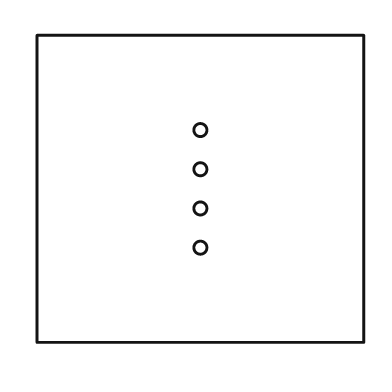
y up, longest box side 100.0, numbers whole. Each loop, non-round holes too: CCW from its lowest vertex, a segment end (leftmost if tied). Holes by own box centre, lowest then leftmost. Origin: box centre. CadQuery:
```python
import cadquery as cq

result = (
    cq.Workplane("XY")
    .moveTo(-50.0, -47.0)
    .lineTo(50.0, -47.0)
    .lineTo(50.0, 47.0)
    .lineTo(-50.0, 47.0)
    .close()
    .moveTo(0.0, -18.0)
    .circle(2.0)
    .moveTo(0.0, -6.0)
    .circle(2.0)
    .moveTo(0.0, 6.0)
    .circle(2.0)
    .moveTo(0.0, 18.0)
    .circle(2.0)
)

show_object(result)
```